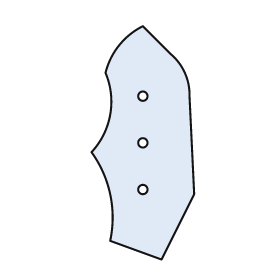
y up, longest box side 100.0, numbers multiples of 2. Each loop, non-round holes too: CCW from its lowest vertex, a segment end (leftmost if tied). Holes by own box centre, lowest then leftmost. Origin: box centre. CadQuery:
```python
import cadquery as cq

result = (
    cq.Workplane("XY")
    .moveTo(8.0, -50.0)
    .lineTo(22.0, -22.0)
    .lineTo(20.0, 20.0)
    .threePointArc((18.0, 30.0), (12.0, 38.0))
    .lineTo(0.0, 50.0)
    .threePointArc((-10.0, 42.0), (-16.0, 30.0))
    .threePointArc((-14.0, 12.0), (-22.0, -4.0))
    .threePointArc((-14.0, -22.0), (-14.0, -42.0))
    .close()
    .moveTo(0.0, -20.0)
    .circle(2.0)
    .moveTo(0.0, 0.0)
    .circle(2.0)
    .moveTo(0.0, 20.0)
    .circle(2.0)
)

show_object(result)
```